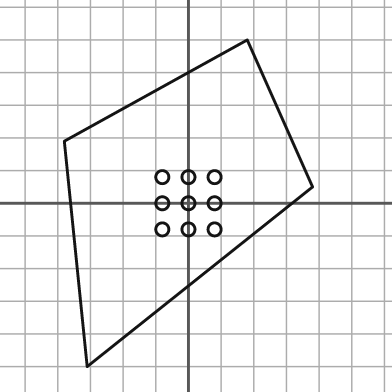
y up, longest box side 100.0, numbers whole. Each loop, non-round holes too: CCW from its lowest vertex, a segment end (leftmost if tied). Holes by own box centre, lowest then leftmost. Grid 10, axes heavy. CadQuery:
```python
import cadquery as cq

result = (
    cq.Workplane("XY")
    .moveTo(-31.0, -50.0)
    .lineTo(38.0, 5.0)
    .lineTo(18.0, 50.0)
    .lineTo(-38.0, 19.0)
    .close()
    .moveTo(-8.0, -8.0)
    .circle(2.0)
    .moveTo(0.0, -8.0)
    .circle(2.0)
    .moveTo(8.0, -8.0)
    .circle(2.0)
    .moveTo(-8.0, 0.0)
    .circle(2.0)
    .moveTo(0.0, 0.0)
    .circle(2.0)
    .moveTo(8.0, 0.0)
    .circle(2.0)
    .moveTo(-8.0, 8.0)
    .circle(2.0)
    .moveTo(0.0, 8.0)
    .circle(2.0)
    .moveTo(8.0, 8.0)
    .circle(2.0)
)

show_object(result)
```